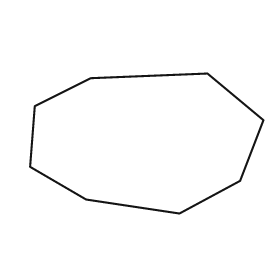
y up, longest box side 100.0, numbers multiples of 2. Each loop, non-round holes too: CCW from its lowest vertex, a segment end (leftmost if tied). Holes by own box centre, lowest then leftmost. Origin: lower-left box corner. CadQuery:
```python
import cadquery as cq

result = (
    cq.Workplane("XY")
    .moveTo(64.0, 0.0)
    .lineTo(90.0, 14.0)
    .lineTo(100.0, 40.0)
    .lineTo(76.0, 60.0)
    .lineTo(26.0, 58.0)
    .lineTo(2.0, 46.0)
    .lineTo(0.0, 20.0)
    .lineTo(24.0, 6.0)
    .close()
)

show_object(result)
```